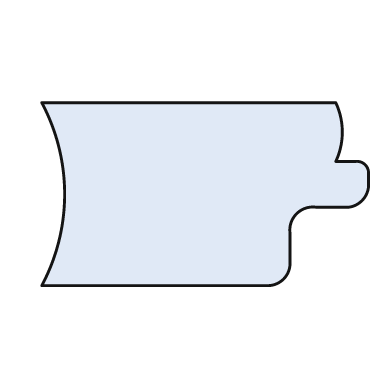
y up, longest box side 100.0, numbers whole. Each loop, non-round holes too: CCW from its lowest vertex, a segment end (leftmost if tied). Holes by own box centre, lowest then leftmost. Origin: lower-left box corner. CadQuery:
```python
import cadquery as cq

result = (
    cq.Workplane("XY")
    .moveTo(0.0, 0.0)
    .lineTo(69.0, 0.0)
    .threePointArc((74.0, 2.0), (76.0, 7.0))
    .lineTo(76.0, 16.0)
    .threePointArc((78.0, 22.0), (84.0, 24.0))
    .lineTo(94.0, 24.0)
    .threePointArc((98.0, 26.0), (100.0, 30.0))
    .lineTo(100.0, 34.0)
    .threePointArc((99.0, 37.0), (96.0, 38.0))
    .lineTo(90.0, 38.0)
    .threePointArc((92.0, 47.0), (90.0, 56.0))
    .lineTo(0.0, 56.0)
    .threePointArc((7.0, 28.0), (0.0, 0.0))
    .close()
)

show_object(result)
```